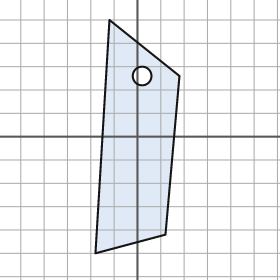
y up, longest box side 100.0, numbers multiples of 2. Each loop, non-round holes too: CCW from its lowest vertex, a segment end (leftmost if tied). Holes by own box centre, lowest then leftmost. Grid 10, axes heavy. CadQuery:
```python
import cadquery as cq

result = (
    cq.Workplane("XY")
    .moveTo(-18.0, -50.0)
    .lineTo(12.0, -42.0)
    .lineTo(18.0, 26.0)
    .lineTo(-12.0, 50.0)
    .close()
    .moveTo(2.0, 26.0)
    .circle(4.0)
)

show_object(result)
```